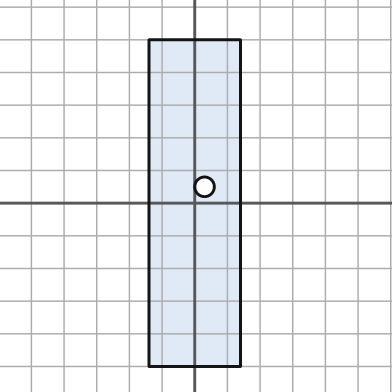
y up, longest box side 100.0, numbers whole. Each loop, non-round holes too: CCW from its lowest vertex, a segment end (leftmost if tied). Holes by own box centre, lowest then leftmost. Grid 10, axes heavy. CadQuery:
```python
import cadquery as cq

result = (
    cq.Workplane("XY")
    .moveTo(-14.0, -50.0)
    .lineTo(14.0, -50.0)
    .lineTo(14.0, 50.0)
    .lineTo(-14.0, 50.0)
    .close()
    .moveTo(3.0, 5.0)
    .circle(3.0)
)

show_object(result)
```